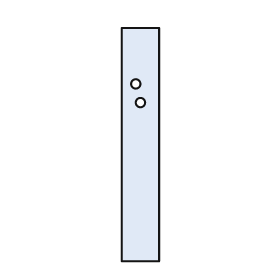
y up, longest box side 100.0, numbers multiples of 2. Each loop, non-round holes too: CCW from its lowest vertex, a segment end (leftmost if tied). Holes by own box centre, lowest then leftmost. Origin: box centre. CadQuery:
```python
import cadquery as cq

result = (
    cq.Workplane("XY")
    .moveTo(-8.0, -50.0)
    .lineTo(8.0, -50.0)
    .lineTo(8.0, 50.0)
    .lineTo(-8.0, 50.0)
    .close()
    .moveTo(0.0, 18.0)
    .circle(2.0)
    .moveTo(-2.0, 26.0)
    .circle(2.0)
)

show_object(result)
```